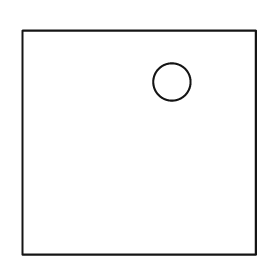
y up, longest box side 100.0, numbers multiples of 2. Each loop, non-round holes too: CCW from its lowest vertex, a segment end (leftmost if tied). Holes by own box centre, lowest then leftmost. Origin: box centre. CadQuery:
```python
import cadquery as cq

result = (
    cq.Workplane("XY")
    .moveTo(-50.0, -48.0)
    .lineTo(50.0, -48.0)
    .lineTo(50.0, 48.0)
    .lineTo(-50.0, 48.0)
    .close()
    .moveTo(14.0, 26.0)
    .circle(8.0)
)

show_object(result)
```